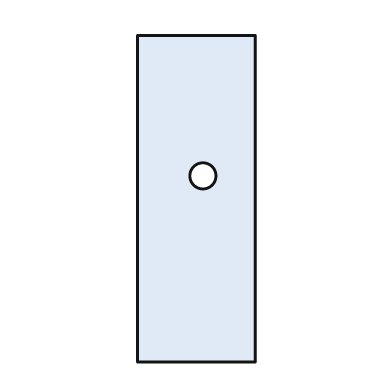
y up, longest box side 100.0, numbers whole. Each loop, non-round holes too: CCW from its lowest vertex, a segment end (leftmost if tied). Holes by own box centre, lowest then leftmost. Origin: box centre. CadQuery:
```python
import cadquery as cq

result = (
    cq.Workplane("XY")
    .moveTo(-18.0, -50.0)
    .lineTo(18.0, -50.0)
    .lineTo(18.0, 50.0)
    .lineTo(-18.0, 50.0)
    .close()
    .moveTo(2.0, 7.0)
    .circle(4.0)
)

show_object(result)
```